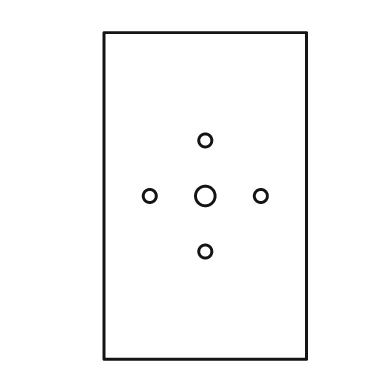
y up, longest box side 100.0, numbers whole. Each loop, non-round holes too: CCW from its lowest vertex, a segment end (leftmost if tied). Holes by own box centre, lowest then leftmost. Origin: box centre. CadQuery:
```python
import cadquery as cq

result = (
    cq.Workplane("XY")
    .moveTo(-31.0, -50.0)
    .lineTo(31.0, -50.0)
    .lineTo(31.0, 50.0)
    .lineTo(-31.0, 50.0)
    .close()
    .moveTo(0.0, -17.0)
    .circle(2.0)
    .moveTo(-17.0, 0.0)
    .circle(2.0)
    .moveTo(0.0, 0.0)
    .circle(3.0)
    .moveTo(17.0, 0.0)
    .circle(2.0)
    .moveTo(0.0, 17.0)
    .circle(2.0)
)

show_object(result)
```